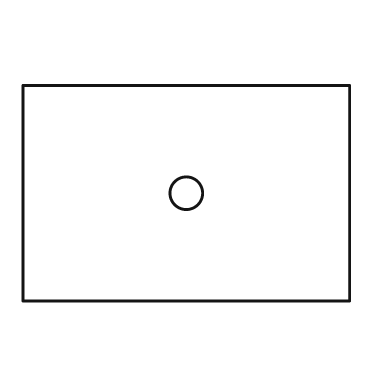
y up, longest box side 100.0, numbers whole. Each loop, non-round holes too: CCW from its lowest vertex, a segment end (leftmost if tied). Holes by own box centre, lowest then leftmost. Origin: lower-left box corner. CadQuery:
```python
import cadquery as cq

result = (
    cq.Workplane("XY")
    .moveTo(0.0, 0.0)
    .lineTo(100.0, 0.0)
    .lineTo(100.0, 66.0)
    .lineTo(0.0, 66.0)
    .close()
    .moveTo(50.0, 33.0)
    .circle(5.0)
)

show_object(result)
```